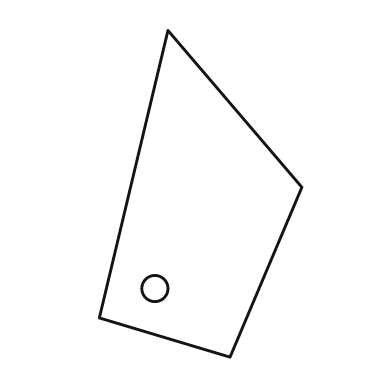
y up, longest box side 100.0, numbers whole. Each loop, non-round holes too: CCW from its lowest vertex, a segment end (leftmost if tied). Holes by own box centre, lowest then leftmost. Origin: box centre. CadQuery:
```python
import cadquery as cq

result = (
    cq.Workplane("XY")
    .moveTo(9.0, -50.0)
    .lineTo(31.0, 2.0)
    .lineTo(-10.0, 50.0)
    .lineTo(-31.0, -38.0)
    .close()
    .moveTo(-14.0, -29.0)
    .circle(4.0)
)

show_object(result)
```